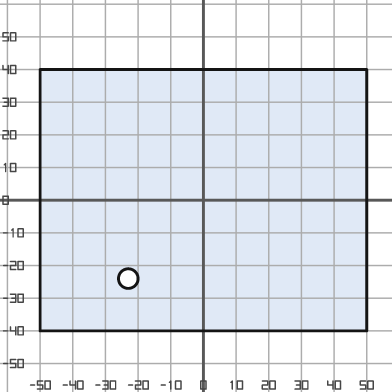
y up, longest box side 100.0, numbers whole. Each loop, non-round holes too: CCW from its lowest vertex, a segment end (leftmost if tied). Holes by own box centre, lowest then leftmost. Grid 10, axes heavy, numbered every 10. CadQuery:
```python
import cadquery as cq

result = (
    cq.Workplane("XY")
    .moveTo(-50.0, -40.0)
    .lineTo(50.0, -40.0)
    .lineTo(50.0, 40.0)
    .lineTo(-50.0, 40.0)
    .close()
    .moveTo(-23.0, -24.0)
    .circle(3.0)
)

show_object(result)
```